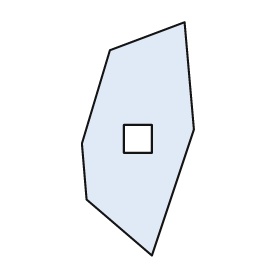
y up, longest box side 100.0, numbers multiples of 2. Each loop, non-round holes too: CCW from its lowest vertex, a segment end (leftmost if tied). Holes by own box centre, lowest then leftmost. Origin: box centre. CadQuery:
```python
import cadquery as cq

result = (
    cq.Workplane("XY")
    .moveTo(6.0, -50.0)
    .lineTo(24.0, 4.0)
    .lineTo(20.0, 50.0)
    .lineTo(-12.0, 38.0)
    .lineTo(-24.0, -2.0)
    .lineTo(-22.0, -26.0)
    .close()
    .moveTo(-6.0, -6.0)
    .lineTo(6.0, -6.0)
    .lineTo(6.0, 6.0)
    .lineTo(-6.0, 6.0)
    .close()
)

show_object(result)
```